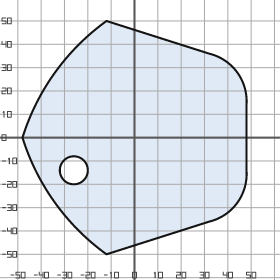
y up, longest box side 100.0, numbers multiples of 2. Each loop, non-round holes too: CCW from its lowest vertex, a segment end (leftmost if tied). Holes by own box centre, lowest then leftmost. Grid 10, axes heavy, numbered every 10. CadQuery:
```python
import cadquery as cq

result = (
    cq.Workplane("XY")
    .moveTo(-12.0, -50.0)
    .lineTo(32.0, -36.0)
    .threePointArc((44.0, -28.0), (48.0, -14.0))
    .lineTo(48.0, 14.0)
    .threePointArc((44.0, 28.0), (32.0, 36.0))
    .lineTo(-12.0, 50.0)
    .threePointArc((-34.0, 28.0), (-48.0, 0.0))
    .threePointArc((-34.0, -28.0), (-12.0, -50.0))
    .close()
    .moveTo(-26.0, -14.0)
    .circle(6.0)
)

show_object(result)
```